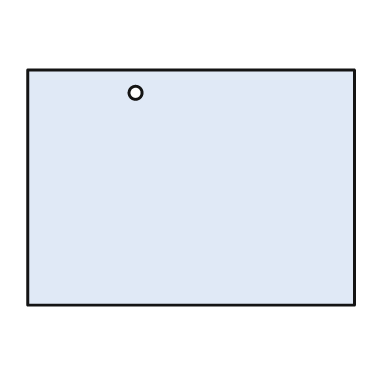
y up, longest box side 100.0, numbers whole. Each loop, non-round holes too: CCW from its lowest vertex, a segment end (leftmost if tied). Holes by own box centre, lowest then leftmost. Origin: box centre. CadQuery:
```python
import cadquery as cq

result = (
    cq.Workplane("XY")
    .moveTo(-50.0, -36.0)
    .lineTo(50.0, -36.0)
    .lineTo(50.0, 36.0)
    .lineTo(-50.0, 36.0)
    .close()
    .moveTo(-17.0, 29.0)
    .circle(2.0)
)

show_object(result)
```